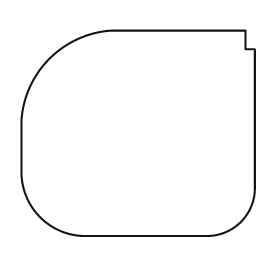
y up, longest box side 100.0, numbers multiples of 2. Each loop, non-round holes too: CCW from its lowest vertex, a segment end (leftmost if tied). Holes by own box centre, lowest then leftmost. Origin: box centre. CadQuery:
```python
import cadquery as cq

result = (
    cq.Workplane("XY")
    .moveTo(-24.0, -44.0)
    .lineTo(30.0, -44.0)
    .threePointArc((44.0, -38.0), (50.0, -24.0))
    .lineTo(50.0, 36.0)
    .lineTo(46.0, 36.0)
    .lineTo(46.0, 44.0)
    .lineTo(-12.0, 44.0)
    .threePointArc((-38.0, 32.0), (-50.0, 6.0))
    .lineTo(-50.0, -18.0)
    .threePointArc((-42.0, -36.0), (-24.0, -44.0))
    .close()
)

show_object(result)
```